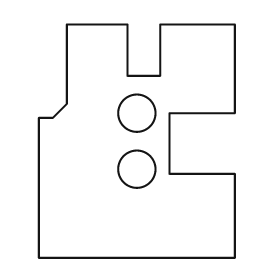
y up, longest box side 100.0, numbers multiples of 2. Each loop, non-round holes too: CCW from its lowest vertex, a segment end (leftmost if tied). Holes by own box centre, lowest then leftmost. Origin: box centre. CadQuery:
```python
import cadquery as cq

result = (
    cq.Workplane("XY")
    .moveTo(-42.0, -50.0)
    .lineTo(42.0, -50.0)
    .lineTo(42.0, -14.0)
    .lineTo(14.0, -14.0)
    .lineTo(14.0, 12.0)
    .lineTo(42.0, 12.0)
    .lineTo(42.0, 50.0)
    .lineTo(10.0, 50.0)
    .lineTo(10.0, 28.0)
    .lineTo(-4.0, 28.0)
    .lineTo(-4.0, 50.0)
    .lineTo(-30.0, 50.0)
    .lineTo(-30.0, 16.0)
    .lineTo(-36.0, 10.0)
    .lineTo(-42.0, 10.0)
    .close()
    .moveTo(0.0, -12.0)
    .circle(8.0)
    .moveTo(0.0, 12.0)
    .circle(8.0)
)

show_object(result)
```